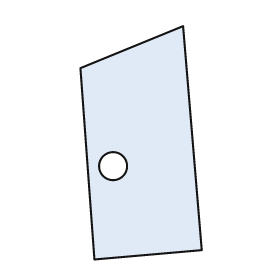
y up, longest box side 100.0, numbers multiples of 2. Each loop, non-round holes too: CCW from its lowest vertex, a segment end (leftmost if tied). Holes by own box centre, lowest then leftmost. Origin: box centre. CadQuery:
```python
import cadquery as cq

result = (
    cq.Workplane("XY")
    .moveTo(-20.0, -50.0)
    .lineTo(26.0, -46.0)
    .lineTo(18.0, 50.0)
    .lineTo(-26.0, 32.0)
    .close()
    .moveTo(-12.0, -10.0)
    .circle(6.0)
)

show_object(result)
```